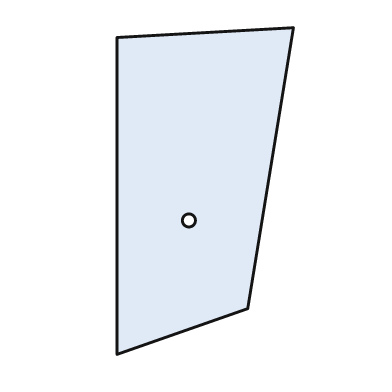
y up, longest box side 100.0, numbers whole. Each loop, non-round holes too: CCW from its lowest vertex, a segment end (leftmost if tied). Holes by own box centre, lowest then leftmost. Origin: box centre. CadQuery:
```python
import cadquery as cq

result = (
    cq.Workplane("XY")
    .moveTo(-27.0, -50.0)
    .lineTo(13.0, -36.0)
    .lineTo(27.0, 50.0)
    .lineTo(-27.0, 47.0)
    .close()
    .moveTo(-5.0, -9.0)
    .circle(2.0)
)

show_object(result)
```